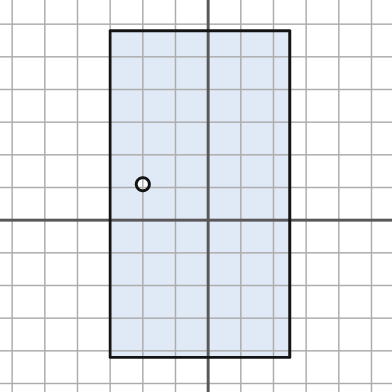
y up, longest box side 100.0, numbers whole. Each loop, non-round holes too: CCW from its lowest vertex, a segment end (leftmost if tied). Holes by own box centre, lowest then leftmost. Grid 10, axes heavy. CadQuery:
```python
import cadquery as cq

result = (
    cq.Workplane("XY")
    .moveTo(-30.0, -42.0)
    .lineTo(25.0, -42.0)
    .lineTo(25.0, 58.0)
    .lineTo(-30.0, 58.0)
    .close()
    .moveTo(-20.0, 11.0)
    .circle(2.0)
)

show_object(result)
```